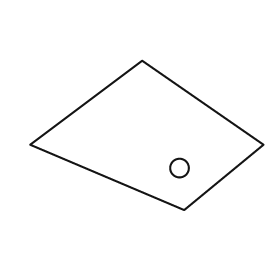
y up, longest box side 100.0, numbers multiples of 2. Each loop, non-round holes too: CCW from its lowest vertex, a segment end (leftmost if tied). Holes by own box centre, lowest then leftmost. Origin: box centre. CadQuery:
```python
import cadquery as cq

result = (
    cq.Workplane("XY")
    .moveTo(16.0, -32.0)
    .lineTo(50.0, -4.0)
    .lineTo(-2.0, 32.0)
    .lineTo(-50.0, -4.0)
    .close()
    .moveTo(14.0, -14.0)
    .circle(4.0)
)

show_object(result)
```